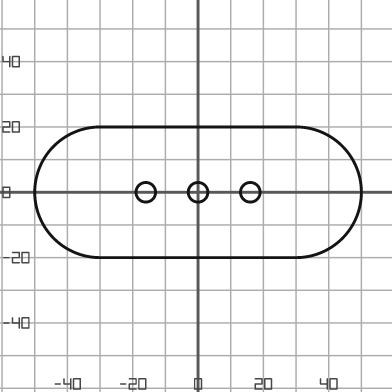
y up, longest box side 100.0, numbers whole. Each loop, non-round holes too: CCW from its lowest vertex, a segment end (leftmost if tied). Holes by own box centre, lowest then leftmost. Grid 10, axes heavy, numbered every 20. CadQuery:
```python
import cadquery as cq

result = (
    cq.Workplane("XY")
    .moveTo(-30.0, -20.0)
    .lineTo(30.0, -20.0)
    .threePointArc((50.0, 0.0), (30.0, 20.0))
    .lineTo(-30.0, 20.0)
    .threePointArc((-50.0, 0.0), (-30.0, -20.0))
    .close()
    .moveTo(-16.0, 0.0)
    .circle(3.0)
    .moveTo(0.0, 0.0)
    .circle(3.0)
    .moveTo(16.0, 0.0)
    .circle(3.0)
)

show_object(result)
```